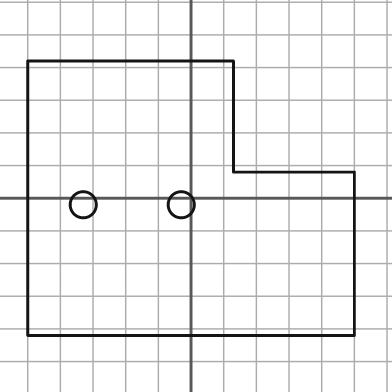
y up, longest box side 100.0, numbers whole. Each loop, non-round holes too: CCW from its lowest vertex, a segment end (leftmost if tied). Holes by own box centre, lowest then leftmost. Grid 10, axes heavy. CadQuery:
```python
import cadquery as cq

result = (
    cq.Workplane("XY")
    .moveTo(-50.0, -42.0)
    .lineTo(50.0, -42.0)
    .lineTo(50.0, 8.0)
    .lineTo(13.0, 8.0)
    .lineTo(13.0, 42.0)
    .lineTo(-50.0, 42.0)
    .close()
    .moveTo(-33.0, -2.0)
    .circle(4.0)
    .moveTo(-3.0, -2.0)
    .circle(4.0)
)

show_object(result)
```